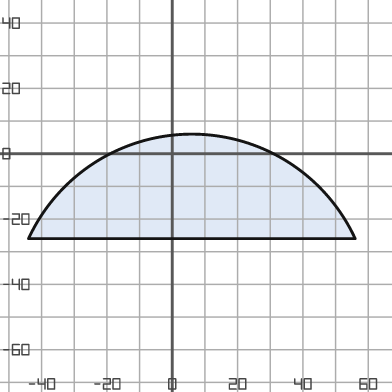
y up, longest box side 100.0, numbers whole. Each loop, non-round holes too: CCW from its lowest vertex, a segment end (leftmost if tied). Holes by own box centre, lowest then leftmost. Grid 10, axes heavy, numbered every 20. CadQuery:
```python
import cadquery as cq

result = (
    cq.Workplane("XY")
    .moveTo(-44.0, -26.0)
    .lineTo(56.0, -26.0)
    .threePointArc((6.0, 6.0), (-44.0, -26.0))
    .close()
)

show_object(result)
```